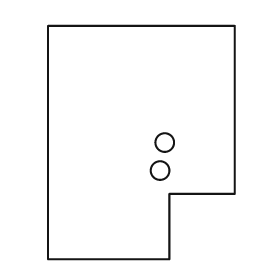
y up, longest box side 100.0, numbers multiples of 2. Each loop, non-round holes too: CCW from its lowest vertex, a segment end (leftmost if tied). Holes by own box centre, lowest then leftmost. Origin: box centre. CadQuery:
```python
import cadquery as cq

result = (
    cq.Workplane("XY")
    .moveTo(-40.0, -50.0)
    .lineTo(12.0, -50.0)
    .lineTo(12.0, -22.0)
    .lineTo(40.0, -22.0)
    .lineTo(40.0, 50.0)
    .lineTo(-40.0, 50.0)
    .close()
    .moveTo(8.0, -12.0)
    .circle(4.0)
    .moveTo(10.0, 0.0)
    .circle(4.0)
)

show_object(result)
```